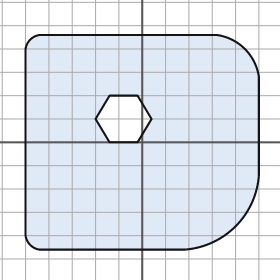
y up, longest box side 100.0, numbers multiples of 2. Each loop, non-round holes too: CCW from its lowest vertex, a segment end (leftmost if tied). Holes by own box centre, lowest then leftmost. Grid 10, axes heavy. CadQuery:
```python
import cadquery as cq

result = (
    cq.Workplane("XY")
    .moveTo(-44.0, -46.0)
    .lineTo(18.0, -46.0)
    .threePointArc((40.0, -36.0), (50.0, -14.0))
    .lineTo(50.0, 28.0)
    .threePointArc((44.0, 40.0), (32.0, 46.0))
    .lineTo(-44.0, 46.0)
    .threePointArc((-48.0, 44.0), (-50.0, 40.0))
    .lineTo(-50.0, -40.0)
    .threePointArc((-48.0, -44.0), (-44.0, -46.0))
    .close()
    .moveTo(-14.0, 0.0)
    .lineTo(-2.0, 0.0)
    .lineTo(4.0, 10.0)
    .lineTo(-2.0, 20.0)
    .lineTo(-14.0, 20.0)
    .lineTo(-20.0, 10.0)
    .close()
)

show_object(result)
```